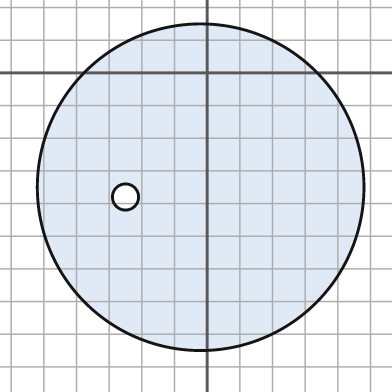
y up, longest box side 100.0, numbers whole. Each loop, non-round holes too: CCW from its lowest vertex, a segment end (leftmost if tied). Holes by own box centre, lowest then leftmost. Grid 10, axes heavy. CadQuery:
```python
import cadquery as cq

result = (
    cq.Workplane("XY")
    .moveTo(-2.0, -35.0)
    .circle(50.0)
    .moveTo(-25.0, -38.0)
    .circle(4.0)
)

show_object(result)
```